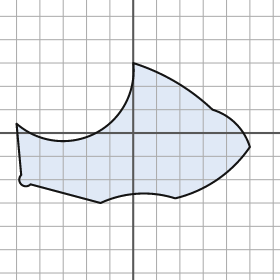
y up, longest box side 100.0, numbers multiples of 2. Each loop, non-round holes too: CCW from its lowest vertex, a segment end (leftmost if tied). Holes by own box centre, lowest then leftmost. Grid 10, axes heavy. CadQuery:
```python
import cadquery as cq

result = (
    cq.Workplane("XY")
    .moveTo(-14.0, -30.0)
    .threePointArc((2.0, -26.0), (18.0, -28.0))
    .threePointArc((36.0, -20.0), (50.0, -6.0))
    .threePointArc((44.0, 4.0), (34.0, 10.0))
    .threePointArc((18.0, 22.0), (0.0, 30.0))
    .threePointArc((-16.0, 0.0), (-50.0, 4.0))
    .lineTo(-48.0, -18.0)
    .threePointArc((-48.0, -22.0), (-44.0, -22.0))
    .close()
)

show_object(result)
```